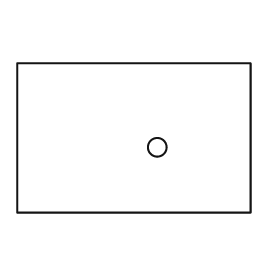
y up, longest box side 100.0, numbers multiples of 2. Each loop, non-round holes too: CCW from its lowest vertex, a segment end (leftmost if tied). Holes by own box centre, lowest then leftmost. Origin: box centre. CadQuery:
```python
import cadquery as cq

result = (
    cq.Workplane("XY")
    .moveTo(-50.0, -32.0)
    .lineTo(50.0, -32.0)
    .lineTo(50.0, 32.0)
    .lineTo(-50.0, 32.0)
    .close()
    .moveTo(10.0, -4.0)
    .circle(4.0)
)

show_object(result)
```